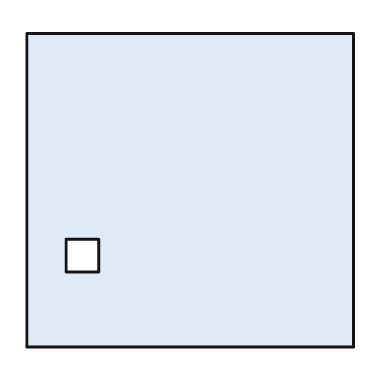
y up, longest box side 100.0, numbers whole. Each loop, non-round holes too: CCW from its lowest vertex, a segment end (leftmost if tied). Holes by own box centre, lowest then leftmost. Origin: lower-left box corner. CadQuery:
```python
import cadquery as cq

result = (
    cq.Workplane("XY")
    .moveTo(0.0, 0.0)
    .lineTo(100.0, 0.0)
    .lineTo(100.0, 96.0)
    .lineTo(0.0, 96.0)
    .close()
    .moveTo(12.0, 23.0)
    .lineTo(22.0, 23.0)
    .lineTo(22.0, 33.0)
    .lineTo(12.0, 33.0)
    .close()
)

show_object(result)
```